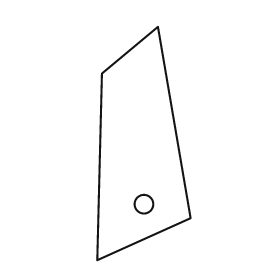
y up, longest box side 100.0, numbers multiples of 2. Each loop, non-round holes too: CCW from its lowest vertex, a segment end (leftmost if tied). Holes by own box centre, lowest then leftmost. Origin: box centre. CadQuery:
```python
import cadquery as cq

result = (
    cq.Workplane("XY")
    .moveTo(-20.0, -50.0)
    .lineTo(20.0, -32.0)
    .lineTo(6.0, 50.0)
    .lineTo(-18.0, 30.0)
    .close()
    .moveTo(0.0, -26.0)
    .circle(4.0)
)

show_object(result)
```